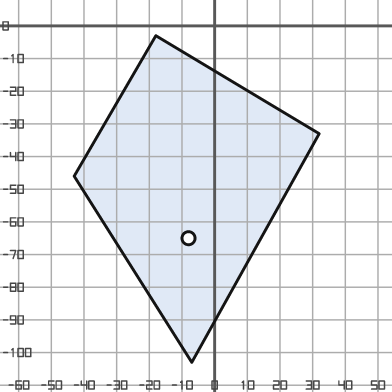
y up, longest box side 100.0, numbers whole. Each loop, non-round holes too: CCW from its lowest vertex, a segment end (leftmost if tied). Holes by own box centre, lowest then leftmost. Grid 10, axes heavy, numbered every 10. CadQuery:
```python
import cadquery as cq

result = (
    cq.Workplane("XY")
    .moveTo(-7.0, -103.0)
    .lineTo(32.0, -33.0)
    .lineTo(-18.0, -3.0)
    .lineTo(-43.0, -46.0)
    .close()
    .moveTo(-8.0, -65.0)
    .circle(2.0)
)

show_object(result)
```